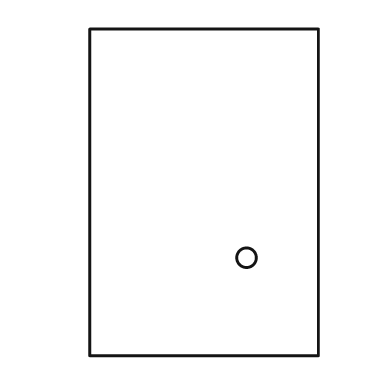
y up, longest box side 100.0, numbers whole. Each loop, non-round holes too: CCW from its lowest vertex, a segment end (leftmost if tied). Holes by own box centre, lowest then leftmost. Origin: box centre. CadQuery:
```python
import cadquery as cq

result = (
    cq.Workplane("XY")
    .moveTo(-35.0, -50.0)
    .lineTo(35.0, -50.0)
    .lineTo(35.0, 50.0)
    .lineTo(-35.0, 50.0)
    .close()
    .moveTo(13.0, -20.0)
    .circle(3.0)
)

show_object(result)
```